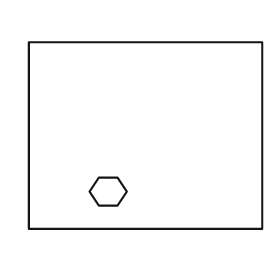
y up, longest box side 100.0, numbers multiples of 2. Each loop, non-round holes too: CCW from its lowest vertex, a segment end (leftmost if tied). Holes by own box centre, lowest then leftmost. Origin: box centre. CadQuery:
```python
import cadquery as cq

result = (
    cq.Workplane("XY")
    .moveTo(-50.0, -40.0)
    .lineTo(50.0, -40.0)
    .lineTo(50.0, 40.0)
    .lineTo(-50.0, 40.0)
    .close()
    .moveTo(-20.0, -30.0)
    .lineTo(-12.0, -30.0)
    .lineTo(-8.0, -24.0)
    .lineTo(-12.0, -18.0)
    .lineTo(-20.0, -18.0)
    .lineTo(-24.0, -24.0)
    .close()
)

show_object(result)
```